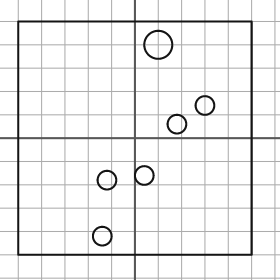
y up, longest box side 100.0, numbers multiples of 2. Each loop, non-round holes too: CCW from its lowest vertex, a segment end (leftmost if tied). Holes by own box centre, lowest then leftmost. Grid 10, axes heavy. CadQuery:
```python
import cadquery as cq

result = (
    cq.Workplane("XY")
    .moveTo(-50.0, -50.0)
    .lineTo(50.0, -50.0)
    .lineTo(50.0, 50.0)
    .lineTo(-50.0, 50.0)
    .close()
    .moveTo(-14.0, -42.0)
    .circle(4.0)
    .moveTo(-12.0, -18.0)
    .circle(4.0)
    .moveTo(4.0, -16.0)
    .circle(4.0)
    .moveTo(18.0, 6.0)
    .circle(4.0)
    .moveTo(30.0, 14.0)
    .circle(4.0)
    .moveTo(10.0, 40.0)
    .circle(6.0)
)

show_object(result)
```